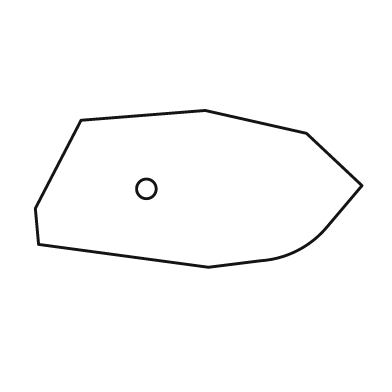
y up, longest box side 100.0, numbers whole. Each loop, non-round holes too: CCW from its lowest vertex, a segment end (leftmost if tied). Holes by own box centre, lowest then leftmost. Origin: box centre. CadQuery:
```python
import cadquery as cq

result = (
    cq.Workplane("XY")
    .moveTo(3.0, -24.0)
    .lineTo(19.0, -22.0)
    .threePointArc((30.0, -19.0), (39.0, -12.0))
    .lineTo(50.0, 1.0)
    .lineTo(33.0, 17.0)
    .lineTo(2.0, 24.0)
    .lineTo(-36.0, 21.0)
    .lineTo(-50.0, -6.0)
    .lineTo(-49.0, -17.0)
    .close()
    .moveTo(-16.0, 0.0)
    .circle(3.0)
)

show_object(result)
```